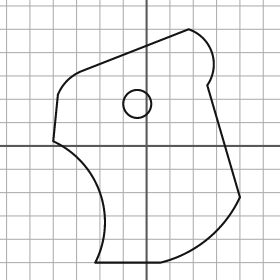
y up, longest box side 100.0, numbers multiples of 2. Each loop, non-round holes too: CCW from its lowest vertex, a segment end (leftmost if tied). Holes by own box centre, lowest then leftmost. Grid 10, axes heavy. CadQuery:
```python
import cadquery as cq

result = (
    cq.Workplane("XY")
    .moveTo(-22.0, -50.0)
    .lineTo(6.0, -50.0)
    .threePointArc((26.0, -40.0), (40.0, -22.0))
    .lineTo(26.0, 26.0)
    .threePointArc((28.0, 40.0), (18.0, 50.0))
    .lineTo(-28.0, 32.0)
    .threePointArc((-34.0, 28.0), (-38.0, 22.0))
    .lineTo(-40.0, 2.0)
    .threePointArc((-20.0, -20.0), (-22.0, -50.0))
    .close()
    .moveTo(-4.0, 18.0)
    .circle(6.0)
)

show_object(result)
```